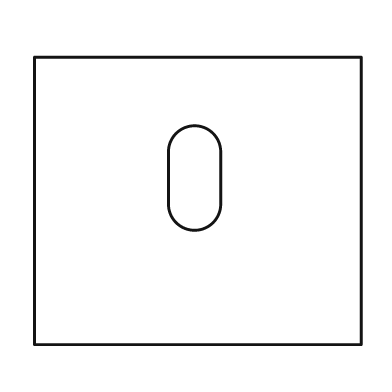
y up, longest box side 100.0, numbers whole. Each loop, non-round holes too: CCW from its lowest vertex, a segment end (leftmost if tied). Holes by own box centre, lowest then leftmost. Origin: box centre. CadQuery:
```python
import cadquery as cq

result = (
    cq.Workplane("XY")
    .moveTo(-50.0, -44.0)
    .lineTo(50.0, -44.0)
    .lineTo(50.0, 44.0)
    .lineTo(-50.0, 44.0)
    .close()
    .moveTo(-9.0, -1.0)
    .threePointArc((-1.0, -9.0), (7.0, -1.0))
    .lineTo(7.0, 15.0)
    .threePointArc((-1.0, 23.0), (-9.0, 15.0))
    .close()
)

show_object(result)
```